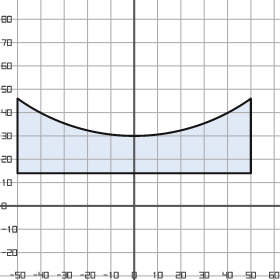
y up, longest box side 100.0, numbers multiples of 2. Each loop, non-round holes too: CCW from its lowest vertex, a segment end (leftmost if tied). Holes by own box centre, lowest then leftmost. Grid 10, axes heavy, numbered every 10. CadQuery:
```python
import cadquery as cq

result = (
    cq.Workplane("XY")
    .moveTo(-50.0, 14.0)
    .lineTo(50.0, 14.0)
    .lineTo(50.0, 46.0)
    .threePointArc((0.0, 30.0), (-50.0, 46.0))
    .close()
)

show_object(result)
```